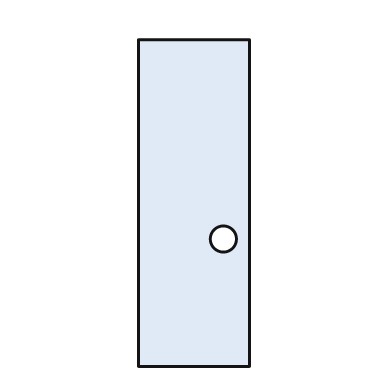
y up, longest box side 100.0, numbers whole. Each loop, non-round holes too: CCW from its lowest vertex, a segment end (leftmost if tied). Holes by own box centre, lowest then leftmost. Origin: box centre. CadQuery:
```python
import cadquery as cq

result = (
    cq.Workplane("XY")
    .moveTo(-17.0, -50.0)
    .lineTo(17.0, -50.0)
    .lineTo(17.0, 50.0)
    .lineTo(-17.0, 50.0)
    .close()
    .moveTo(9.0, -11.0)
    .circle(4.0)
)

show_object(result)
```